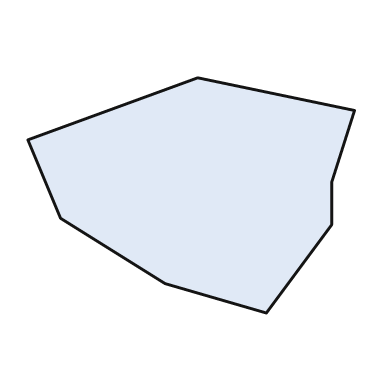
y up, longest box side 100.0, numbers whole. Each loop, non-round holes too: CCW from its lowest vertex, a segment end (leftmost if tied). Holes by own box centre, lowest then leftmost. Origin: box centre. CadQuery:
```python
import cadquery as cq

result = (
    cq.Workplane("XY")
    .moveTo(23.0, -36.0)
    .lineTo(43.0, -9.0)
    .lineTo(43.0, 4.0)
    .lineTo(50.0, 26.0)
    .lineTo(2.0, 36.0)
    .lineTo(-50.0, 17.0)
    .lineTo(-40.0, -7.0)
    .lineTo(-8.0, -27.0)
    .close()
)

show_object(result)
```